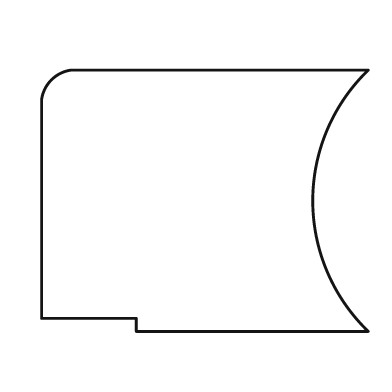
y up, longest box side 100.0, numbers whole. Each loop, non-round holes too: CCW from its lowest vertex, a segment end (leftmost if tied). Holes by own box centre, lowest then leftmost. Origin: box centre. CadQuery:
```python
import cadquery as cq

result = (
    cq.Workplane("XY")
    .moveTo(-21.0, -40.0)
    .lineTo(50.0, -40.0)
    .threePointArc((33.0, 0.0), (50.0, 40.0))
    .lineTo(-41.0, 40.0)
    .threePointArc((-47.0, 37.0), (-50.0, 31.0))
    .lineTo(-50.0, -36.0)
    .lineTo(-21.0, -36.0)
    .close()
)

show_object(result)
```